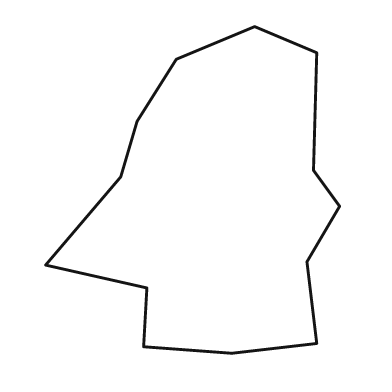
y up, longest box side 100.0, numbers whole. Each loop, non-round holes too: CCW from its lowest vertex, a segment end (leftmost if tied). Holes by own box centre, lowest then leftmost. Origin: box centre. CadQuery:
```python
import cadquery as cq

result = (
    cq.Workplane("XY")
    .moveTo(12.0, -50.0)
    .lineTo(38.0, -47.0)
    .lineTo(35.0, -22.0)
    .lineTo(45.0, -5.0)
    .lineTo(37.0, 6.0)
    .lineTo(38.0, 42.0)
    .lineTo(19.0, 50.0)
    .lineTo(-5.0, 40.0)
    .lineTo(-17.0, 21.0)
    .lineTo(-22.0, 4.0)
    .lineTo(-45.0, -23.0)
    .lineTo(-14.0, -30.0)
    .lineTo(-15.0, -48.0)
    .close()
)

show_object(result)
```